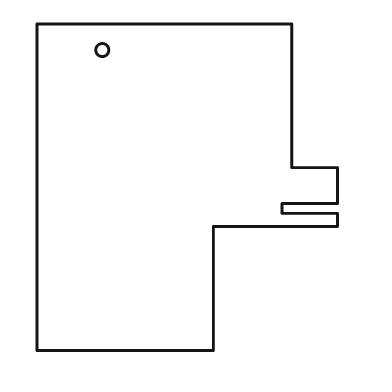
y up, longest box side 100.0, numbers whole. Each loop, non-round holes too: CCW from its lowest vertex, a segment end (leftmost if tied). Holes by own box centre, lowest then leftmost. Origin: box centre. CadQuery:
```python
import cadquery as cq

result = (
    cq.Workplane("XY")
    .moveTo(-46.0, -50.0)
    .lineTo(8.0, -50.0)
    .lineTo(8.0, -12.0)
    .lineTo(46.0, -12.0)
    .lineTo(46.0, -8.0)
    .lineTo(29.0, -8.0)
    .lineTo(29.0, -5.0)
    .lineTo(46.0, -5.0)
    .lineTo(46.0, 6.0)
    .lineTo(32.0, 6.0)
    .lineTo(32.0, 50.0)
    .lineTo(-46.0, 50.0)
    .close()
    .moveTo(-26.0, 42.0)
    .circle(2.0)
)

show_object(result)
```